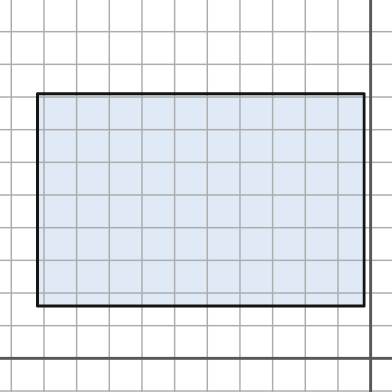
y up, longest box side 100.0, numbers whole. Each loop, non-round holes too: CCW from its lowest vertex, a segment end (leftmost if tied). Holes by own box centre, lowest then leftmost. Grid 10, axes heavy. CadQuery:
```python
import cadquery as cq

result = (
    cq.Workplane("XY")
    .moveTo(-102.0, 16.0)
    .lineTo(-2.0, 16.0)
    .lineTo(-2.0, 81.0)
    .lineTo(-102.0, 81.0)
    .close()
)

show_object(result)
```